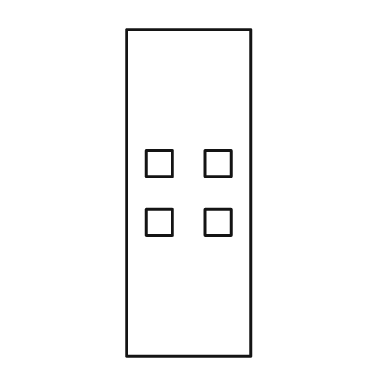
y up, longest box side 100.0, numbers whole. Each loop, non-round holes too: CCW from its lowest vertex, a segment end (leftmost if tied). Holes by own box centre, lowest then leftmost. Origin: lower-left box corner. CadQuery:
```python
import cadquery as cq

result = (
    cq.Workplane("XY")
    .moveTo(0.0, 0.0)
    .lineTo(38.0, 0.0)
    .lineTo(38.0, 100.0)
    .lineTo(0.0, 100.0)
    .close()
    .moveTo(6.0, 37.0)
    .lineTo(14.0, 37.0)
    .lineTo(14.0, 45.0)
    .lineTo(6.0, 45.0)
    .close()
    .moveTo(24.0, 37.0)
    .lineTo(32.0, 37.0)
    .lineTo(32.0, 45.0)
    .lineTo(24.0, 45.0)
    .close()
    .moveTo(6.0, 55.0)
    .lineTo(14.0, 55.0)
    .lineTo(14.0, 63.0)
    .lineTo(6.0, 63.0)
    .close()
    .moveTo(24.0, 55.0)
    .lineTo(32.0, 55.0)
    .lineTo(32.0, 63.0)
    .lineTo(24.0, 63.0)
    .close()
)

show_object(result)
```